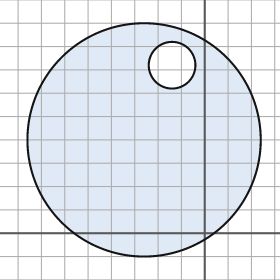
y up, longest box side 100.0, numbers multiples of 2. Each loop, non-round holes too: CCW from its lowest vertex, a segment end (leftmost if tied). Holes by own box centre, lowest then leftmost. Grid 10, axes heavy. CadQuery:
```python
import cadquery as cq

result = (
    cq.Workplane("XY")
    .moveTo(-26.0, 40.0)
    .circle(50.0)
    .moveTo(-14.0, 72.0)
    .circle(10.0)
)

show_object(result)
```